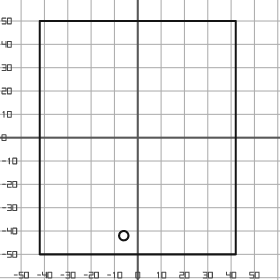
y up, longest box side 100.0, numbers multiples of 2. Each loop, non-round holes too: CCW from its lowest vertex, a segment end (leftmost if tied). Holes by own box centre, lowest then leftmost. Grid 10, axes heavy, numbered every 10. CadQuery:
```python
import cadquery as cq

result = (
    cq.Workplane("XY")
    .moveTo(-42.0, -50.0)
    .lineTo(42.0, -50.0)
    .lineTo(42.0, 50.0)
    .lineTo(-42.0, 50.0)
    .close()
    .moveTo(-6.0, -42.0)
    .circle(2.0)
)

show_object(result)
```